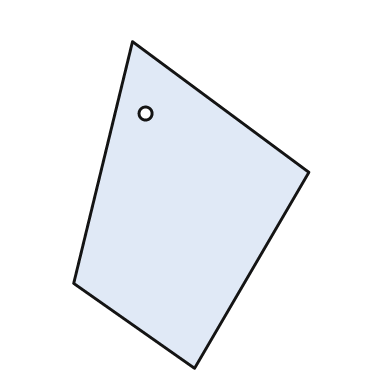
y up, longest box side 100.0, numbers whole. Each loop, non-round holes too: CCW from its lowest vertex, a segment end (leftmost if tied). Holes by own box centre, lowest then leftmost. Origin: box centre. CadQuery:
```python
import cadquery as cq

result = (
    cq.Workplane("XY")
    .moveTo(1.0, -50.0)
    .lineTo(36.0, 10.0)
    .lineTo(-18.0, 50.0)
    .lineTo(-36.0, -24.0)
    .close()
    .moveTo(-14.0, 28.0)
    .circle(2.0)
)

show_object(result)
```